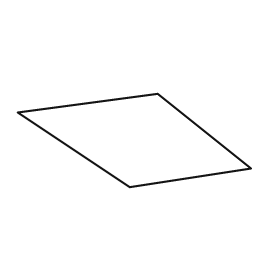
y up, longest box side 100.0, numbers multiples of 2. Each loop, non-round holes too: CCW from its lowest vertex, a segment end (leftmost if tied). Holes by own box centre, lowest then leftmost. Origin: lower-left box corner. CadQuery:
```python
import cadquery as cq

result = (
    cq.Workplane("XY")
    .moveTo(48.0, 0.0)
    .lineTo(100.0, 8.0)
    .lineTo(60.0, 40.0)
    .lineTo(0.0, 32.0)
    .close()
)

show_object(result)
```